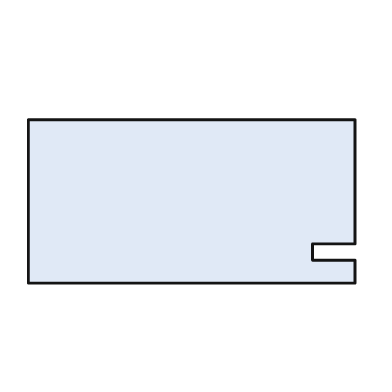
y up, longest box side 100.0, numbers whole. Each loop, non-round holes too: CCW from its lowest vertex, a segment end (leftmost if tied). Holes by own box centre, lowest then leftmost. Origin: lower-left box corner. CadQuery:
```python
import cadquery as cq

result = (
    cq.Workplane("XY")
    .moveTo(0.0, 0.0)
    .lineTo(100.0, 0.0)
    .lineTo(100.0, 7.0)
    .lineTo(87.0, 7.0)
    .lineTo(87.0, 12.0)
    .lineTo(100.0, 12.0)
    .lineTo(100.0, 50.0)
    .lineTo(0.0, 50.0)
    .close()
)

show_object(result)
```